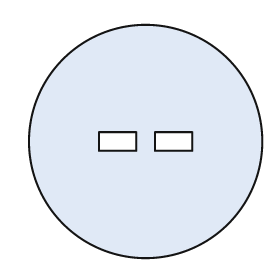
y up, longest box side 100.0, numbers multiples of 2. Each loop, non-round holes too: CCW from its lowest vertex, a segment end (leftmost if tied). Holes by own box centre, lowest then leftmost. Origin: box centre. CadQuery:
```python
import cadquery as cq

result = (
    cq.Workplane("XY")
    .moveTo(0.0, 0.0)
    .circle(50.0)
    .moveTo(-20.0, -4.0)
    .lineTo(-4.0, -4.0)
    .lineTo(-4.0, 4.0)
    .lineTo(-20.0, 4.0)
    .close()
    .moveTo(4.0, -4.0)
    .lineTo(20.0, -4.0)
    .lineTo(20.0, 4.0)
    .lineTo(4.0, 4.0)
    .close()
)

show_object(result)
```